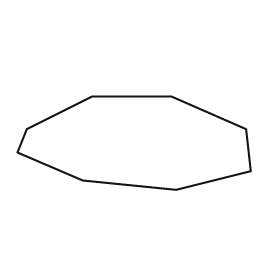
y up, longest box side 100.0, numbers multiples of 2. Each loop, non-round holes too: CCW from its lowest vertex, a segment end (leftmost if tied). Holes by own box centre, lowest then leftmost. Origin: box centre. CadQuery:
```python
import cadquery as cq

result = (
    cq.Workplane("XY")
    .moveTo(18.0, -20.0)
    .lineTo(50.0, -12.0)
    .lineTo(48.0, 6.0)
    .lineTo(16.0, 20.0)
    .lineTo(-18.0, 20.0)
    .lineTo(-46.0, 6.0)
    .lineTo(-50.0, -4.0)
    .lineTo(-22.0, -16.0)
    .close()
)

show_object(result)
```